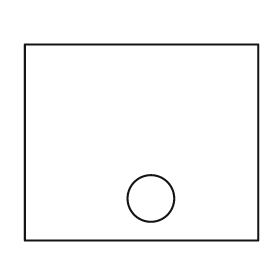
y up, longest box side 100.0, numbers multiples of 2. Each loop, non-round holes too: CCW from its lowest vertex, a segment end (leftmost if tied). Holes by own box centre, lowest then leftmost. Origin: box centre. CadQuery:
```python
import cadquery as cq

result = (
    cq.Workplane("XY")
    .moveTo(-50.0, -42.0)
    .lineTo(50.0, -42.0)
    .lineTo(50.0, 42.0)
    .lineTo(-50.0, 42.0)
    .close()
    .moveTo(4.0, -24.0)
    .circle(10.0)
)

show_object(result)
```